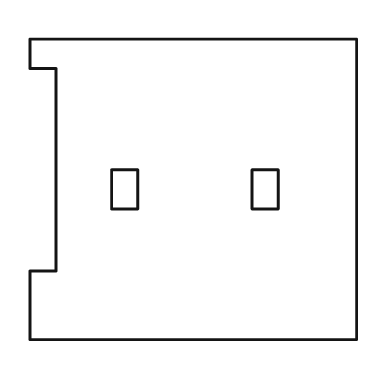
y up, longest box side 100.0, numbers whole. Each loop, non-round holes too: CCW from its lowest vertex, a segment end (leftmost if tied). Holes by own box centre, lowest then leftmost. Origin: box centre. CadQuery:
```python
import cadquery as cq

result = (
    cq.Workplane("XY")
    .moveTo(-50.0, -46.0)
    .lineTo(50.0, -46.0)
    .lineTo(50.0, 46.0)
    .lineTo(-50.0, 46.0)
    .lineTo(-50.0, 37.0)
    .lineTo(-42.0, 37.0)
    .lineTo(-42.0, -25.0)
    .lineTo(-50.0, -25.0)
    .close()
    .moveTo(-25.0, -6.0)
    .lineTo(-17.0, -6.0)
    .lineTo(-17.0, 6.0)
    .lineTo(-25.0, 6.0)
    .close()
    .moveTo(18.0, -6.0)
    .lineTo(26.0, -6.0)
    .lineTo(26.0, 6.0)
    .lineTo(18.0, 6.0)
    .close()
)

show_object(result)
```